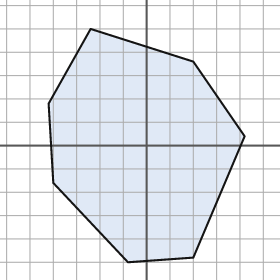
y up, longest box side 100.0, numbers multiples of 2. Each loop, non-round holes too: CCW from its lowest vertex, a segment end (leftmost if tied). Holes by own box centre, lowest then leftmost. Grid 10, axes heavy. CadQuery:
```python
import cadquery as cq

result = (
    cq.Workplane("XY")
    .moveTo(-8.0, -50.0)
    .lineTo(20.0, -48.0)
    .lineTo(42.0, 4.0)
    .lineTo(20.0, 36.0)
    .lineTo(-24.0, 50.0)
    .lineTo(-42.0, 18.0)
    .lineTo(-40.0, -16.0)
    .close()
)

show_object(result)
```